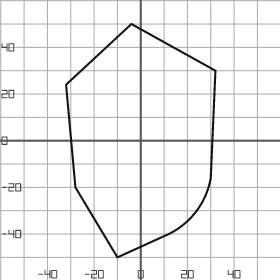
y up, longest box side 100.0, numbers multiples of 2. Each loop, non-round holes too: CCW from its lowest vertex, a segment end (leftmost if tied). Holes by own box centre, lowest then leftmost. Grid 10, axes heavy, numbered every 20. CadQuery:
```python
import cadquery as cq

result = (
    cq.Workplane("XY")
    .moveTo(-10.0, -50.0)
    .lineTo(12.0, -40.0)
    .threePointArc((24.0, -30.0), (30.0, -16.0))
    .lineTo(32.0, 30.0)
    .lineTo(-4.0, 50.0)
    .lineTo(-32.0, 24.0)
    .lineTo(-28.0, -20.0)
    .close()
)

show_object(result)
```